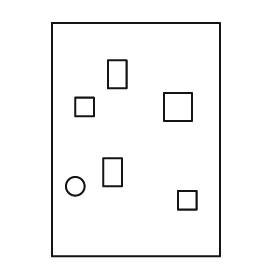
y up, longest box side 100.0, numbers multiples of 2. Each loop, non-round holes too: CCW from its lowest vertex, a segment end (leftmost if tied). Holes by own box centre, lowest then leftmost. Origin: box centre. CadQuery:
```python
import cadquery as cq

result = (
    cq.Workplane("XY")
    .moveTo(-36.0, -50.0)
    .lineTo(36.0, -50.0)
    .lineTo(36.0, 50.0)
    .lineTo(-36.0, 50.0)
    .close()
    .moveTo(18.0, -30.0)
    .lineTo(26.0, -30.0)
    .lineTo(26.0, -22.0)
    .lineTo(18.0, -22.0)
    .close()
    .moveTo(-26.0, -20.0)
    .circle(4.0)
    .moveTo(-14.0, -20.0)
    .lineTo(-6.0, -20.0)
    .lineTo(-6.0, -8.0)
    .lineTo(-14.0, -8.0)
    .close()
    .moveTo(-26.0, 10.0)
    .lineTo(-18.0, 10.0)
    .lineTo(-18.0, 18.0)
    .lineTo(-26.0, 18.0)
    .close()
    .moveTo(12.0, 8.0)
    .lineTo(24.0, 8.0)
    .lineTo(24.0, 20.0)
    .lineTo(12.0, 20.0)
    .close()
    .moveTo(-12.0, 22.0)
    .lineTo(-4.0, 22.0)
    .lineTo(-4.0, 34.0)
    .lineTo(-12.0, 34.0)
    .close()
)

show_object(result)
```